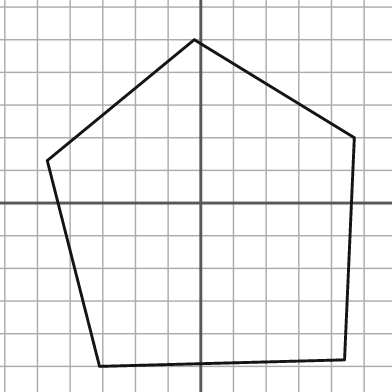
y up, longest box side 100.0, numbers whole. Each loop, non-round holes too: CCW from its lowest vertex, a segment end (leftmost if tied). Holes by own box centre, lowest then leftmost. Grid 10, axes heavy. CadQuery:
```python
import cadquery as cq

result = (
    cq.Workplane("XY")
    .moveTo(-31.0, -50.0)
    .lineTo(44.0, -48.0)
    .lineTo(47.0, 20.0)
    .lineTo(-2.0, 50.0)
    .lineTo(-47.0, 13.0)
    .close()
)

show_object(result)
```